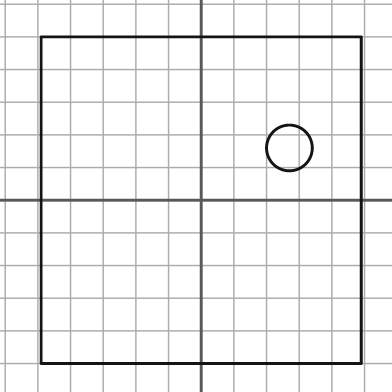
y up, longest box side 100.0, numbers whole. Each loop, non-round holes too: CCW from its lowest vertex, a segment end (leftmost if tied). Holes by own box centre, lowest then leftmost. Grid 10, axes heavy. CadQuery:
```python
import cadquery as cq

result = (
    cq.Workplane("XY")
    .moveTo(-49.0, -50.0)
    .lineTo(49.0, -50.0)
    .lineTo(49.0, 50.0)
    .lineTo(-49.0, 50.0)
    .close()
    .moveTo(27.0, 16.0)
    .circle(7.0)
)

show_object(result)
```